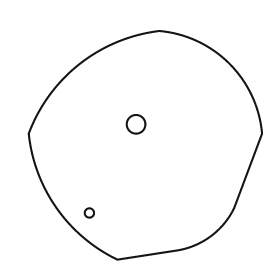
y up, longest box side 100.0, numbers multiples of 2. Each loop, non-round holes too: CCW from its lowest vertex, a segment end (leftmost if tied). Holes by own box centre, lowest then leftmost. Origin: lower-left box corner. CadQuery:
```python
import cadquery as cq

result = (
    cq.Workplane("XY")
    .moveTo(38.0, 0.0)
    .lineTo(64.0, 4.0)
    .threePointArc((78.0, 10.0), (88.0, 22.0))
    .lineTo(100.0, 54.0)
    .threePointArc((86.0, 84.0), (56.0, 98.0))
    .threePointArc((22.0, 84.0), (0.0, 54.0))
    .threePointArc((12.0, 22.0), (38.0, 0.0))
    .close()
    .moveTo(26.0, 20.0)
    .circle(2.0)
    .moveTo(46.0, 58.0)
    .circle(4.0)
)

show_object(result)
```